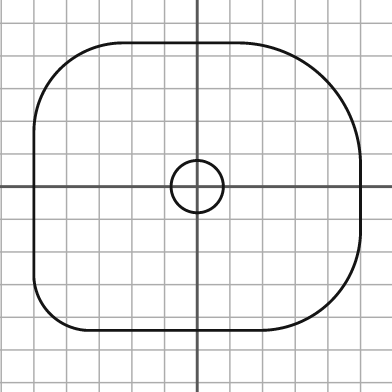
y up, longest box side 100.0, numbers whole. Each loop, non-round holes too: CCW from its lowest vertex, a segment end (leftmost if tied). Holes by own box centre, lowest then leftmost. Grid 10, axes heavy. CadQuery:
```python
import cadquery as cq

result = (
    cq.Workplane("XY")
    .moveTo(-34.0, -44.0)
    .lineTo(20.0, -44.0)
    .threePointArc((41.0, -35.0), (50.0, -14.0))
    .lineTo(50.0, 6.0)
    .threePointArc((39.0, 33.0), (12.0, 44.0))
    .lineTo(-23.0, 44.0)
    .threePointArc((-42.0, 36.0), (-50.0, 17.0))
    .lineTo(-50.0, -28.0)
    .threePointArc((-45.0, -39.0), (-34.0, -44.0))
    .close()
    .moveTo(0.0, 0.0)
    .circle(8.0)
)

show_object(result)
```